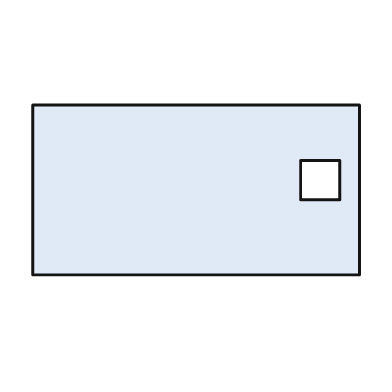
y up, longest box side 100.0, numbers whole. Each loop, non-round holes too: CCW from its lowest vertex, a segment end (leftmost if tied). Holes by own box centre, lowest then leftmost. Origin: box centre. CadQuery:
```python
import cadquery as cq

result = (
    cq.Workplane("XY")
    .moveTo(-50.0, -26.0)
    .lineTo(50.0, -26.0)
    .lineTo(50.0, 26.0)
    .lineTo(-50.0, 26.0)
    .close()
    .moveTo(32.0, -3.0)
    .lineTo(44.0, -3.0)
    .lineTo(44.0, 9.0)
    .lineTo(32.0, 9.0)
    .close()
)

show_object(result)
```